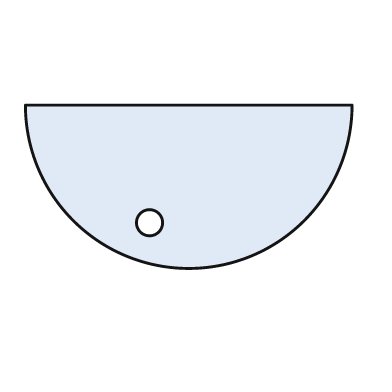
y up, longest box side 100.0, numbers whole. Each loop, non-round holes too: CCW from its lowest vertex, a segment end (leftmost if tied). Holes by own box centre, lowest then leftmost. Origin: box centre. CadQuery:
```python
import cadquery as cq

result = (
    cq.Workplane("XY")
    .moveTo(-50.0, 25.0)
    .threePointArc((0.0, -25.0), (50.0, 25.0))
    .close()
    .moveTo(-12.0, -11.0)
    .circle(4.0)
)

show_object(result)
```